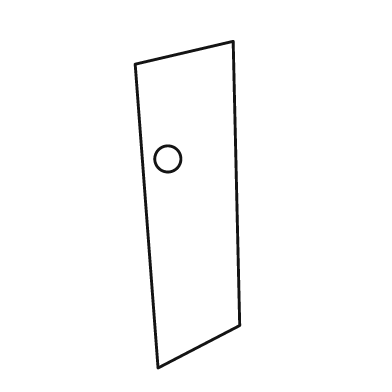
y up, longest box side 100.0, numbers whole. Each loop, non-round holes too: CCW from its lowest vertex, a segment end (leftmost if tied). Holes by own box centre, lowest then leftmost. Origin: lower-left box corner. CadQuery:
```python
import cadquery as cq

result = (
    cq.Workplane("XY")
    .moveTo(7.0, 0.0)
    .lineTo(32.0, 13.0)
    .lineTo(30.0, 100.0)
    .lineTo(0.0, 93.0)
    .close()
    .moveTo(10.0, 64.0)
    .circle(4.0)
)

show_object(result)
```